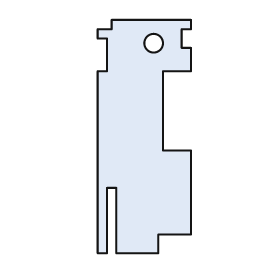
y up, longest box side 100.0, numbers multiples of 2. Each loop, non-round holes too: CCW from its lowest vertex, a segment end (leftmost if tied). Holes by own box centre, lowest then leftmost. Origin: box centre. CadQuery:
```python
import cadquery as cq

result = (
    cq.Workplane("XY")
    .moveTo(-20.0, -50.0)
    .lineTo(-16.0, -50.0)
    .lineTo(-16.0, -22.0)
    .lineTo(-12.0, -22.0)
    .lineTo(-12.0, -50.0)
    .lineTo(6.0, -50.0)
    .lineTo(6.0, -42.0)
    .lineTo(20.0, -42.0)
    .lineTo(20.0, -6.0)
    .lineTo(8.0, -6.0)
    .lineTo(8.0, 28.0)
    .lineTo(20.0, 28.0)
    .lineTo(20.0, 38.0)
    .lineTo(16.0, 38.0)
    .lineTo(16.0, 46.0)
    .lineTo(20.0, 46.0)
    .lineTo(20.0, 50.0)
    .lineTo(-14.0, 50.0)
    .lineTo(-14.0, 46.0)
    .lineTo(-20.0, 46.0)
    .lineTo(-20.0, 42.0)
    .lineTo(-16.0, 42.0)
    .lineTo(-16.0, 28.0)
    .lineTo(-20.0, 28.0)
    .close()
    .moveTo(4.0, 40.0)
    .circle(4.0)
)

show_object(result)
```